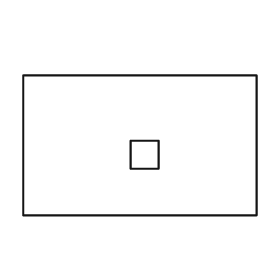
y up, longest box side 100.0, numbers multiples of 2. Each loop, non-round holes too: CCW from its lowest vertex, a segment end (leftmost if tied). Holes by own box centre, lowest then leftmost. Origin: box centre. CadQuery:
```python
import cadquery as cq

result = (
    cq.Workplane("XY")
    .moveTo(-50.0, -30.0)
    .lineTo(50.0, -30.0)
    .lineTo(50.0, 30.0)
    .lineTo(-50.0, 30.0)
    .close()
    .moveTo(-4.0, -10.0)
    .lineTo(8.0, -10.0)
    .lineTo(8.0, 2.0)
    .lineTo(-4.0, 2.0)
    .close()
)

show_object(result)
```